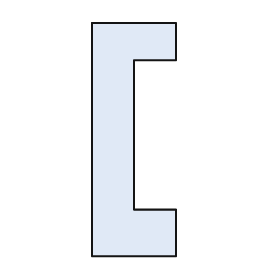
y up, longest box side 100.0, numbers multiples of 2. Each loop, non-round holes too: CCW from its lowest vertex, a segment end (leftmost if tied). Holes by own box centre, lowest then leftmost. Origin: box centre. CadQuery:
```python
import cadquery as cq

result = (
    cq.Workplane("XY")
    .moveTo(-18.0, -50.0)
    .lineTo(18.0, -50.0)
    .lineTo(18.0, -30.0)
    .lineTo(0.0, -30.0)
    .lineTo(0.0, 34.0)
    .lineTo(18.0, 34.0)
    .lineTo(18.0, 50.0)
    .lineTo(-18.0, 50.0)
    .close()
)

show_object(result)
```